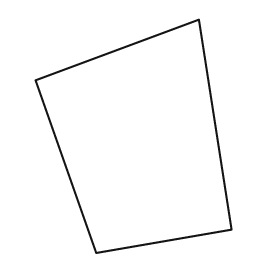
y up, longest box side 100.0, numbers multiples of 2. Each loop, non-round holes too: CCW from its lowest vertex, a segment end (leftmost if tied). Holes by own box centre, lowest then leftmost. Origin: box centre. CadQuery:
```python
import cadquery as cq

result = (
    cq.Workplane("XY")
    .moveTo(-16.0, -50.0)
    .lineTo(42.0, -40.0)
    .lineTo(28.0, 50.0)
    .lineTo(-42.0, 24.0)
    .close()
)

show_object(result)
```